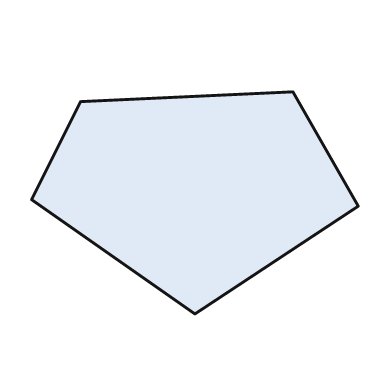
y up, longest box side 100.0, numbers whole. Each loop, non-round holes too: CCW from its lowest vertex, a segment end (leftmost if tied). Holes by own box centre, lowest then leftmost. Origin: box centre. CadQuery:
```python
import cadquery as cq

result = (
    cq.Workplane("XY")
    .moveTo(0.0, -34.0)
    .lineTo(50.0, -1.0)
    .lineTo(30.0, 34.0)
    .lineTo(-35.0, 31.0)
    .lineTo(-50.0, 1.0)
    .close()
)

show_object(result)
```